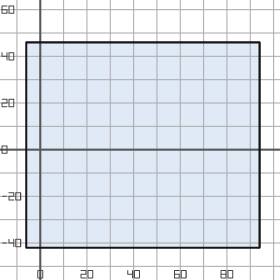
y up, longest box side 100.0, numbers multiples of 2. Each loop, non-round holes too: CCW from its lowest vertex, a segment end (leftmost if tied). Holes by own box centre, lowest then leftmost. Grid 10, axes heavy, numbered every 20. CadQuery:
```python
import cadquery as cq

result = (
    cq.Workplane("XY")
    .moveTo(-6.0, -42.0)
    .lineTo(94.0, -42.0)
    .lineTo(94.0, 46.0)
    .lineTo(-6.0, 46.0)
    .close()
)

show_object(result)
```